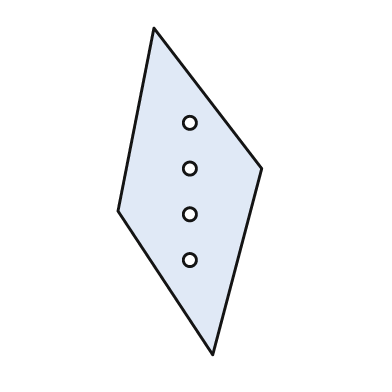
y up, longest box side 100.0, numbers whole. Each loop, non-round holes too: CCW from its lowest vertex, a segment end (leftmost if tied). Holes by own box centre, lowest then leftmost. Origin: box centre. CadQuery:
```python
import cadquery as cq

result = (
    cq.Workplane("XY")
    .moveTo(7.0, -50.0)
    .lineTo(22.0, 7.0)
    .lineTo(-11.0, 50.0)
    .lineTo(-22.0, -6.0)
    .close()
    .moveTo(0.0, -21.0)
    .circle(2.0)
    .moveTo(0.0, -7.0)
    .circle(2.0)
    .moveTo(0.0, 7.0)
    .circle(2.0)
    .moveTo(0.0, 21.0)
    .circle(2.0)
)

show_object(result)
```